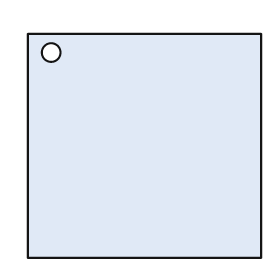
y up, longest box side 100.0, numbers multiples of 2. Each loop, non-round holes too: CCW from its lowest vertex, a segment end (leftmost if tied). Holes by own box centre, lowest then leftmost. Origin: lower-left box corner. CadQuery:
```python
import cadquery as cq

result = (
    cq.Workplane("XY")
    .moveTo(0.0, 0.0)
    .lineTo(100.0, 0.0)
    .lineTo(100.0, 96.0)
    .lineTo(0.0, 96.0)
    .close()
    .moveTo(10.0, 88.0)
    .circle(4.0)
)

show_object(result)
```